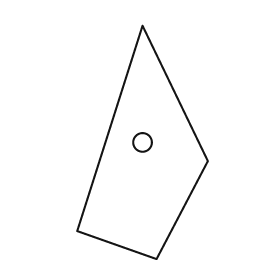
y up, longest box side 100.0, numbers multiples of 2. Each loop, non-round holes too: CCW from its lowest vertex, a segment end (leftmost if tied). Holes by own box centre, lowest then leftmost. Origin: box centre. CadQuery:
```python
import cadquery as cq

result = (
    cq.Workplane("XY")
    .moveTo(6.0, -50.0)
    .lineTo(28.0, -8.0)
    .lineTo(0.0, 50.0)
    .lineTo(-28.0, -38.0)
    .close()
    .moveTo(0.0, 0.0)
    .circle(4.0)
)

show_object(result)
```